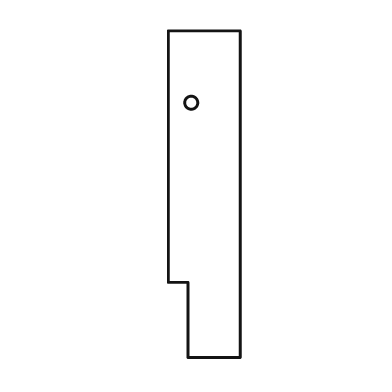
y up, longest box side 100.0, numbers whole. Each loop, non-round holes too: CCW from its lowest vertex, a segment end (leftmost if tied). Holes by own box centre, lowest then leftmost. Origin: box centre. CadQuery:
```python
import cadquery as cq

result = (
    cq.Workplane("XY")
    .moveTo(-5.0, -50.0)
    .lineTo(11.0, -50.0)
    .lineTo(11.0, 50.0)
    .lineTo(-11.0, 50.0)
    .lineTo(-11.0, -27.0)
    .lineTo(-5.0, -27.0)
    .close()
    .moveTo(-4.0, 28.0)
    .circle(2.0)
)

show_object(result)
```